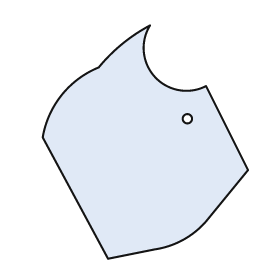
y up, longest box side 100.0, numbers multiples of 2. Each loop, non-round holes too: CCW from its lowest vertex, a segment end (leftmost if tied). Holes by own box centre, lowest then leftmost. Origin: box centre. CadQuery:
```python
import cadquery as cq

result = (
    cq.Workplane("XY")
    .moveTo(-16.0, -50.0)
    .lineTo(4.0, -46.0)
    .threePointArc((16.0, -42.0), (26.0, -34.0))
    .lineTo(44.0, -12.0)
    .lineTo(26.0, 24.0)
    .threePointArc((4.0, 28.0), (2.0, 50.0))
    .threePointArc((-10.0, 42.0), (-20.0, 32.0))
    .threePointArc((-36.0, 20.0), (-44.0, 2.0))
    .close()
    .moveTo(18.0, 10.0)
    .circle(2.0)
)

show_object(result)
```